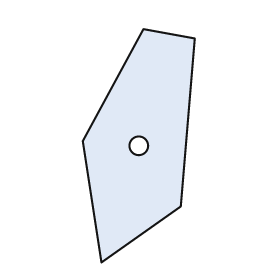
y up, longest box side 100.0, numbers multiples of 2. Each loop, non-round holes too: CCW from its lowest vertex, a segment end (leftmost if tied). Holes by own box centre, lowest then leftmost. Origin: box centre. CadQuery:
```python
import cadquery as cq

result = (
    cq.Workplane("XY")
    .moveTo(-16.0, -50.0)
    .lineTo(18.0, -26.0)
    .lineTo(24.0, 46.0)
    .lineTo(2.0, 50.0)
    .lineTo(-24.0, 2.0)
    .close()
    .moveTo(0.0, 0.0)
    .circle(4.0)
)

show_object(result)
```